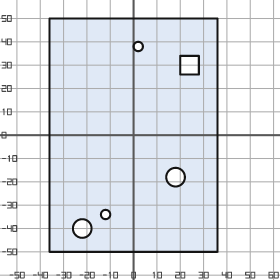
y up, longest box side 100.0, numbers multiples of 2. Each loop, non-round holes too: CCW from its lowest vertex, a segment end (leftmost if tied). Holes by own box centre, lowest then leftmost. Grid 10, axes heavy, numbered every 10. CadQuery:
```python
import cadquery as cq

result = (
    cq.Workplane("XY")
    .moveTo(-36.0, -50.0)
    .lineTo(36.0, -50.0)
    .lineTo(36.0, 50.0)
    .lineTo(-36.0, 50.0)
    .close()
    .moveTo(-22.0, -40.0)
    .circle(4.0)
    .moveTo(-12.0, -34.0)
    .circle(2.0)
    .moveTo(18.0, -18.0)
    .circle(4.0)
    .moveTo(20.0, 26.0)
    .lineTo(28.0, 26.0)
    .lineTo(28.0, 34.0)
    .lineTo(20.0, 34.0)
    .close()
    .moveTo(2.0, 38.0)
    .circle(2.0)
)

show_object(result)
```